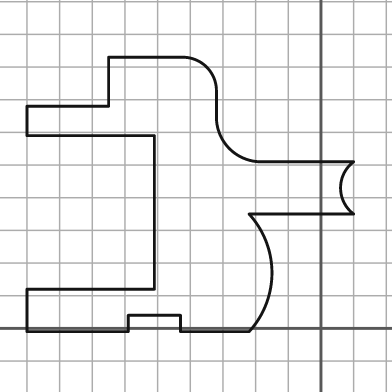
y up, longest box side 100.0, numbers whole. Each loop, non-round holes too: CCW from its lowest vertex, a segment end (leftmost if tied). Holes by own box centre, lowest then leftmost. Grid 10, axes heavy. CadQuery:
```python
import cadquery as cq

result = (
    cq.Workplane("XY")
    .moveTo(-90.0, -1.0)
    .lineTo(-59.0, -1.0)
    .lineTo(-59.0, 4.0)
    .lineTo(-43.0, 4.0)
    .lineTo(-43.0, -1.0)
    .lineTo(-22.0, -1.0)
    .threePointArc((-15.0, 17.0), (-22.0, 35.0))
    .lineTo(10.0, 35.0)
    .threePointArc((6.0, 43.0), (10.0, 51.0))
    .lineTo(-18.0, 51.0)
    .threePointArc((-28.0, 55.0), (-32.0, 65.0))
    .lineTo(-32.0, 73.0)
    .threePointArc((-35.0, 80.0), (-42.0, 83.0))
    .lineTo(-65.0, 83.0)
    .lineTo(-65.0, 68.0)
    .lineTo(-90.0, 68.0)
    .lineTo(-90.0, 59.0)
    .lineTo(-51.0, 59.0)
    .lineTo(-51.0, 12.0)
    .lineTo(-90.0, 12.0)
    .close()
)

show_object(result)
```